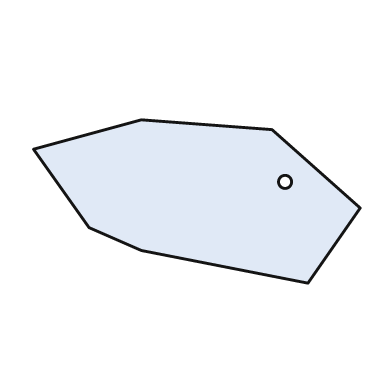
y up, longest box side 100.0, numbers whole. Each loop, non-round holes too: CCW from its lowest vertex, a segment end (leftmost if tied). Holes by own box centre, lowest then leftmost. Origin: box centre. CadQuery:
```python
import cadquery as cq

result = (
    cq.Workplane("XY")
    .moveTo(34.0, -25.0)
    .lineTo(50.0, -2.0)
    .lineTo(23.0, 22.0)
    .lineTo(-17.0, 25.0)
    .lineTo(-50.0, 16.0)
    .lineTo(-33.0, -8.0)
    .lineTo(-17.0, -15.0)
    .close()
    .moveTo(27.0, 6.0)
    .circle(2.0)
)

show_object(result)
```